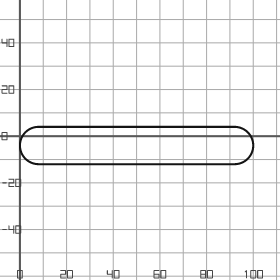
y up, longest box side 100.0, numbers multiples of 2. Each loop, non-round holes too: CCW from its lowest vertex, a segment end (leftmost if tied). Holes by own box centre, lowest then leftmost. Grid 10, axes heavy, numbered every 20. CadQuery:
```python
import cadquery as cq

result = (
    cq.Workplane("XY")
    .moveTo(8.0, -12.0)
    .lineTo(92.0, -12.0)
    .threePointArc((100.0, -4.0), (92.0, 4.0))
    .lineTo(8.0, 4.0)
    .threePointArc((0.0, -4.0), (8.0, -12.0))
    .close()
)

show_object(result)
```